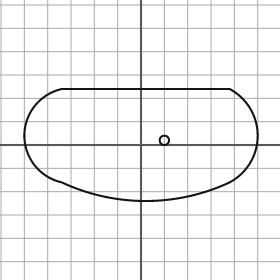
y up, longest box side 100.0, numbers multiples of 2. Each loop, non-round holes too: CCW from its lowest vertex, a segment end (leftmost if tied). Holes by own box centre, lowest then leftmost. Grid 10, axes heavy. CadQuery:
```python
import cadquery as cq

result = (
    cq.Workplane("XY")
    .moveTo(-34.0, -16.0)
    .threePointArc((2.0, -24.0), (38.0, -16.0))
    .threePointArc((50.0, 4.0), (38.0, 24.0))
    .lineTo(-34.0, 24.0)
    .threePointArc((-50.0, 4.0), (-34.0, -16.0))
    .close()
    .moveTo(10.0, 2.0)
    .circle(2.0)
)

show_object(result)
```